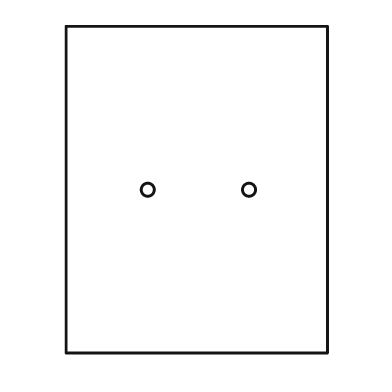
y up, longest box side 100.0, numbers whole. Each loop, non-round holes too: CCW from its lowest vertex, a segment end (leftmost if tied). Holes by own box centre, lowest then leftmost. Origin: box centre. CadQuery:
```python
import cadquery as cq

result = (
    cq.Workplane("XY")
    .moveTo(-40.0, -50.0)
    .lineTo(40.0, -50.0)
    .lineTo(40.0, 50.0)
    .lineTo(-40.0, 50.0)
    .close()
    .moveTo(-15.0, 0.0)
    .circle(2.0)
    .moveTo(16.0, 0.0)
    .circle(2.0)
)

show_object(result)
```